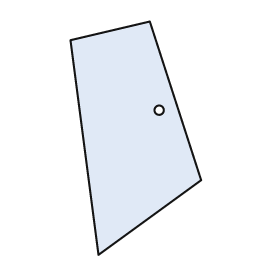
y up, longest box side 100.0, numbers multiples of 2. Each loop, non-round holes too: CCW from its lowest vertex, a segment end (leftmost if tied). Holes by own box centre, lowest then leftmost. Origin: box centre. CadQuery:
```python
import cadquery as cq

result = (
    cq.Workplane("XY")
    .moveTo(-16.0, -50.0)
    .lineTo(28.0, -18.0)
    .lineTo(6.0, 50.0)
    .lineTo(-28.0, 42.0)
    .close()
    .moveTo(10.0, 12.0)
    .circle(2.0)
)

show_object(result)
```